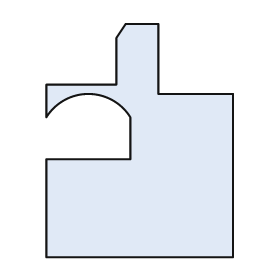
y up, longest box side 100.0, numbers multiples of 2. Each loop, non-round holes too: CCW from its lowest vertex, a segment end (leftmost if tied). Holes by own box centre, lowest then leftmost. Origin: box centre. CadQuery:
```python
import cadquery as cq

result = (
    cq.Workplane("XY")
    .moveTo(-40.0, -50.0)
    .lineTo(40.0, -50.0)
    .lineTo(40.0, 20.0)
    .lineTo(8.0, 20.0)
    .lineTo(8.0, 50.0)
    .lineTo(-6.0, 50.0)
    .lineTo(-10.0, 44.0)
    .lineTo(-10.0, 24.0)
    .lineTo(-40.0, 24.0)
    .lineTo(-40.0, 10.0)
    .threePointArc((-22.0, 20.0), (-4.0, 10.0))
    .lineTo(-4.0, -8.0)
    .lineTo(-40.0, -8.0)
    .close()
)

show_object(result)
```